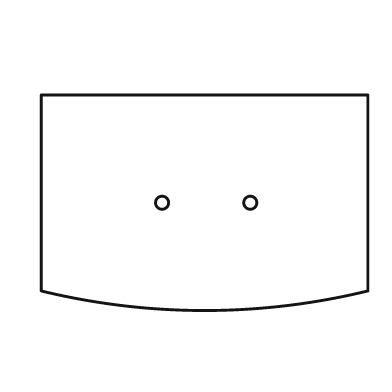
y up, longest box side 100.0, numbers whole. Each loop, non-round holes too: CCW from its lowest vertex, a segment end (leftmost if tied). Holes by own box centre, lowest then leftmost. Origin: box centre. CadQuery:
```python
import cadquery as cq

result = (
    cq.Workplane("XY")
    .moveTo(-50.0, -27.0)
    .threePointArc((0.0, -33.0), (50.0, -27.0))
    .lineTo(50.0, 33.0)
    .lineTo(-50.0, 33.0)
    .close()
    .moveTo(-13.0, 0.0)
    .circle(2.0)
    .moveTo(14.0, 0.0)
    .circle(2.0)
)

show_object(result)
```